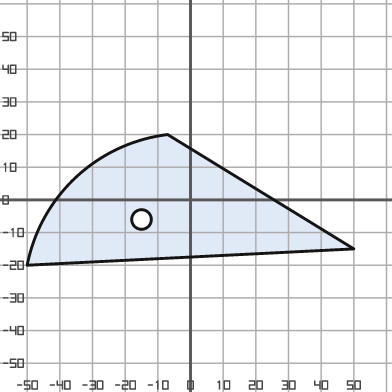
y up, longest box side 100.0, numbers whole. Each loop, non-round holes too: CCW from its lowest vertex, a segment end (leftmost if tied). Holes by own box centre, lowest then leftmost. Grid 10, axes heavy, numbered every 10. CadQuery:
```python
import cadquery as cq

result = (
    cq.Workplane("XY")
    .moveTo(-50.0, -20.0)
    .lineTo(50.0, -15.0)
    .lineTo(-7.0, 20.0)
    .threePointArc((-35.0, 7.0), (-50.0, -20.0))
    .close()
    .moveTo(-15.0, -6.0)
    .circle(3.0)
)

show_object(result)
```